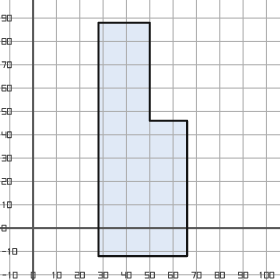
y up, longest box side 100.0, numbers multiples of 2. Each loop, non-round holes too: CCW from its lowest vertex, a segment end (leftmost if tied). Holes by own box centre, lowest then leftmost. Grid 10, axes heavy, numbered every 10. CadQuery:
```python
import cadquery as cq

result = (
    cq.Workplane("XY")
    .moveTo(28.0, -12.0)
    .lineTo(66.0, -12.0)
    .lineTo(66.0, 46.0)
    .lineTo(50.0, 46.0)
    .lineTo(50.0, 88.0)
    .lineTo(28.0, 88.0)
    .close()
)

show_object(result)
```